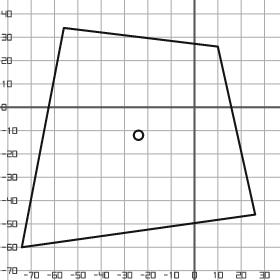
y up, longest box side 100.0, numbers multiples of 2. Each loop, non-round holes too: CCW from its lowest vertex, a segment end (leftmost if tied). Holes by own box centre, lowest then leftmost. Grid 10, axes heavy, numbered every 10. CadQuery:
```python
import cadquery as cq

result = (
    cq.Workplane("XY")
    .moveTo(-74.0, -60.0)
    .lineTo(26.0, -46.0)
    .lineTo(10.0, 26.0)
    .lineTo(-56.0, 34.0)
    .close()
    .moveTo(-24.0, -12.0)
    .circle(2.0)
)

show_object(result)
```